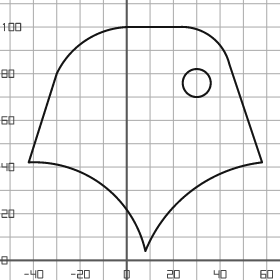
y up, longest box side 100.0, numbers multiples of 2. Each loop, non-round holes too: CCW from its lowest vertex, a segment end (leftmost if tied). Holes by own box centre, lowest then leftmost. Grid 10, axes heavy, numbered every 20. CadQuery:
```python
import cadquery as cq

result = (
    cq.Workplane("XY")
    .moveTo(8.0, 4.0)
    .threePointArc((28.0, 30.0), (58.0, 42.0))
    .lineTo(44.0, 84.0)
    .threePointArc((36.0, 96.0), (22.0, 100.0))
    .lineTo(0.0, 100.0)
    .threePointArc((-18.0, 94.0), (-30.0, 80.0))
    .lineTo(-42.0, 42.0)
    .threePointArc((-10.0, 32.0), (8.0, 4.0))
    .close()
    .moveTo(30.0, 76.0)
    .circle(6.0)
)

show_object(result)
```